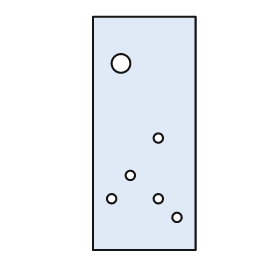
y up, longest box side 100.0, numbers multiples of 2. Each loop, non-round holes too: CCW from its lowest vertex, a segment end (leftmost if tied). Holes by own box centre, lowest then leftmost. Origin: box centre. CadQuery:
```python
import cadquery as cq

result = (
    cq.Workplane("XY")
    .moveTo(-22.0, -50.0)
    .lineTo(22.0, -50.0)
    .lineTo(22.0, 50.0)
    .lineTo(-22.0, 50.0)
    .close()
    .moveTo(14.0, -36.0)
    .circle(2.0)
    .moveTo(-14.0, -28.0)
    .circle(2.0)
    .moveTo(6.0, -28.0)
    .circle(2.0)
    .moveTo(-6.0, -18.0)
    .circle(2.0)
    .moveTo(6.0, -2.0)
    .circle(2.0)
    .moveTo(-10.0, 30.0)
    .circle(4.0)
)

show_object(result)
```